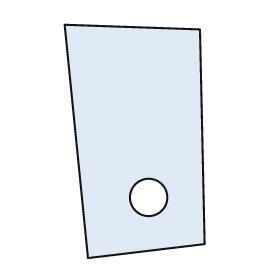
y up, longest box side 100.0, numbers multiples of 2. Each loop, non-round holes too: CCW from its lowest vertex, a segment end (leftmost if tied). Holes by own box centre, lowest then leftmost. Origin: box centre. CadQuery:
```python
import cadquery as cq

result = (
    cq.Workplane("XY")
    .moveTo(-20.0, -50.0)
    .lineTo(30.0, -44.0)
    .lineTo(28.0, 48.0)
    .lineTo(-30.0, 50.0)
    .close()
    .moveTo(6.0, -24.0)
    .circle(8.0)
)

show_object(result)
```